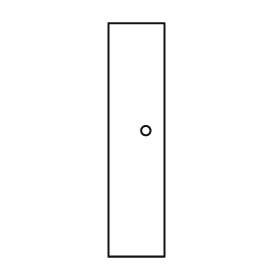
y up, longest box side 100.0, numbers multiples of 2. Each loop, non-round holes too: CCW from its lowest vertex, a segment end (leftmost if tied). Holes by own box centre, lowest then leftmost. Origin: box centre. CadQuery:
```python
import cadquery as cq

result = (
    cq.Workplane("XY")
    .moveTo(-12.0, -50.0)
    .lineTo(12.0, -50.0)
    .lineTo(12.0, 50.0)
    .lineTo(-12.0, 50.0)
    .close()
    .moveTo(4.0, 4.0)
    .circle(2.0)
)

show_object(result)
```